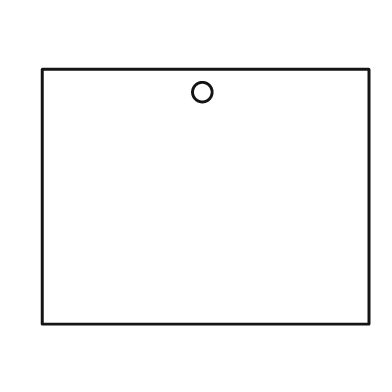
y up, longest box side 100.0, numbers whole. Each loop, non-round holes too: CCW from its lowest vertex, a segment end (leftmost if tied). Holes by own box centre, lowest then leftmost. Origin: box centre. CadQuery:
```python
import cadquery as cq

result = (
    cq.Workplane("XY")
    .moveTo(-50.0, -39.0)
    .lineTo(50.0, -39.0)
    .lineTo(50.0, 39.0)
    .lineTo(-50.0, 39.0)
    .close()
    .moveTo(-1.0, 32.0)
    .circle(3.0)
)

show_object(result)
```